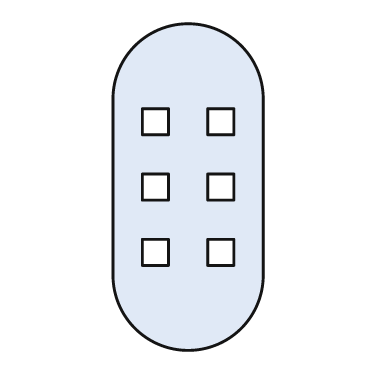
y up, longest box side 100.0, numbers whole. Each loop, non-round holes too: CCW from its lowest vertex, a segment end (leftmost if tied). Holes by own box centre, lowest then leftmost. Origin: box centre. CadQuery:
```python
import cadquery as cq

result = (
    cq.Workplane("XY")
    .moveTo(-23.0, -27.0)
    .threePointArc((0.0, -50.0), (23.0, -27.0))
    .lineTo(23.0, 27.0)
    .threePointArc((0.0, 50.0), (-23.0, 27.0))
    .close()
    .moveTo(-14.0, -24.0)
    .lineTo(-6.0, -24.0)
    .lineTo(-6.0, -16.0)
    .lineTo(-14.0, -16.0)
    .close()
    .moveTo(6.0, -24.0)
    .lineTo(14.0, -24.0)
    .lineTo(14.0, -16.0)
    .lineTo(6.0, -16.0)
    .close()
    .moveTo(-14.0, -4.0)
    .lineTo(-6.0, -4.0)
    .lineTo(-6.0, 4.0)
    .lineTo(-14.0, 4.0)
    .close()
    .moveTo(6.0, -4.0)
    .lineTo(14.0, -4.0)
    .lineTo(14.0, 4.0)
    .lineTo(6.0, 4.0)
    .close()
    .moveTo(-14.0, 16.0)
    .lineTo(-6.0, 16.0)
    .lineTo(-6.0, 24.0)
    .lineTo(-14.0, 24.0)
    .close()
    .moveTo(6.0, 16.0)
    .lineTo(14.0, 16.0)
    .lineTo(14.0, 24.0)
    .lineTo(6.0, 24.0)
    .close()
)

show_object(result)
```